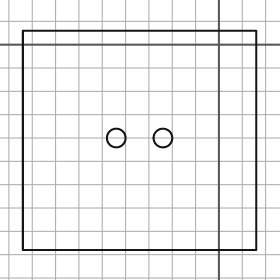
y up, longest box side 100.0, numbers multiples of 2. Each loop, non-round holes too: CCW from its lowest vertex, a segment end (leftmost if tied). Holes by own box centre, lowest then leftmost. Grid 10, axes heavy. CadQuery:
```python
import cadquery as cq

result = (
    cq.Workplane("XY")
    .moveTo(-84.0, -88.0)
    .lineTo(16.0, -88.0)
    .lineTo(16.0, 6.0)
    .lineTo(-84.0, 6.0)
    .close()
    .moveTo(-44.0, -40.0)
    .circle(4.0)
    .moveTo(-24.0, -40.0)
    .circle(4.0)
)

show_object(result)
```